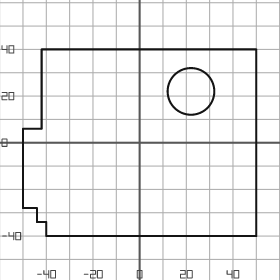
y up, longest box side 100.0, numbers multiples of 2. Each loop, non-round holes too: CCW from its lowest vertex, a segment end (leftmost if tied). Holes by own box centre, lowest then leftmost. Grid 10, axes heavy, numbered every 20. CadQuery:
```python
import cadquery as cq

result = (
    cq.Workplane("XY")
    .moveTo(-40.0, -40.0)
    .lineTo(50.0, -40.0)
    .lineTo(50.0, 40.0)
    .lineTo(-42.0, 40.0)
    .lineTo(-42.0, 6.0)
    .lineTo(-50.0, 6.0)
    .lineTo(-50.0, -28.0)
    .lineTo(-44.0, -28.0)
    .lineTo(-44.0, -34.0)
    .lineTo(-40.0, -34.0)
    .close()
    .moveTo(22.0, 22.0)
    .circle(10.0)
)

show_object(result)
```